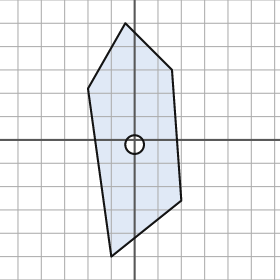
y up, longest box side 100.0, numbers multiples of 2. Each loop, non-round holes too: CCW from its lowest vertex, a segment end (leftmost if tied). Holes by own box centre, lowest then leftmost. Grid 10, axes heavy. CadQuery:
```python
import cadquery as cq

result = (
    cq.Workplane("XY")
    .moveTo(-10.0, -50.0)
    .lineTo(20.0, -26.0)
    .lineTo(16.0, 30.0)
    .lineTo(-4.0, 50.0)
    .lineTo(-20.0, 22.0)
    .close()
    .moveTo(0.0, -2.0)
    .circle(4.0)
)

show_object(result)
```